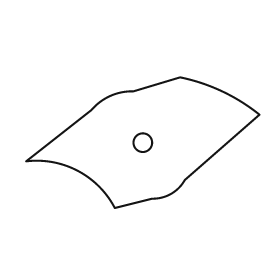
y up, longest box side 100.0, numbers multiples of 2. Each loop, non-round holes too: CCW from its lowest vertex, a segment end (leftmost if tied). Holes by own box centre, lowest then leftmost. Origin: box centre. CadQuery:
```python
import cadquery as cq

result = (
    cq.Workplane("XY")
    .moveTo(-12.0, -28.0)
    .lineTo(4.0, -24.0)
    .threePointArc((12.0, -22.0), (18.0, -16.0))
    .lineTo(50.0, 12.0)
    .threePointArc((34.0, 22.0), (16.0, 28.0))
    .lineTo(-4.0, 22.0)
    .threePointArc((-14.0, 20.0), (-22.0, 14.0))
    .lineTo(-50.0, -8.0)
    .threePointArc((-28.0, -12.0), (-12.0, -28.0))
    .close()
    .moveTo(0.0, 0.0)
    .circle(4.0)
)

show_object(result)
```